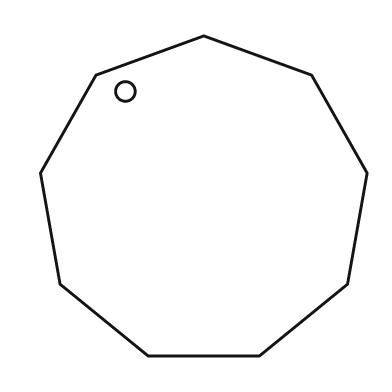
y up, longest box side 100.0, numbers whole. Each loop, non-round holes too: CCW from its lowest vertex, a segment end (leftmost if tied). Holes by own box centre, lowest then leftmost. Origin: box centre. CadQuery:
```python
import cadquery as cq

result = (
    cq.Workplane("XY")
    .moveTo(-17.0, -49.0)
    .lineTo(17.0, -49.0)
    .lineTo(44.0, -27.0)
    .lineTo(50.0, 7.0)
    .lineTo(33.0, 37.0)
    .lineTo(0.0, 49.0)
    .lineTo(-33.0, 37.0)
    .lineTo(-50.0, 7.0)
    .lineTo(-44.0, -27.0)
    .close()
    .moveTo(-24.0, 32.0)
    .circle(3.0)
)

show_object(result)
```